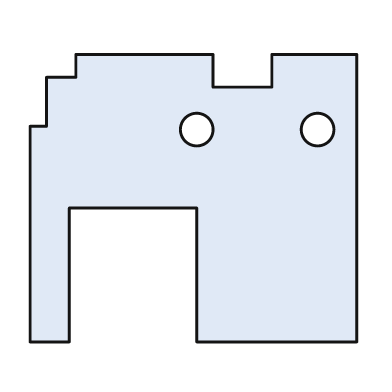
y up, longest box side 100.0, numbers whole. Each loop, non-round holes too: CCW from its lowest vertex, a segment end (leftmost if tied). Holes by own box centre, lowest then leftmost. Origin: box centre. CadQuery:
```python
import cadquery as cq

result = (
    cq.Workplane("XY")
    .moveTo(-50.0, -44.0)
    .lineTo(-38.0, -44.0)
    .lineTo(-38.0, -3.0)
    .lineTo(1.0, -3.0)
    .lineTo(1.0, -44.0)
    .lineTo(50.0, -44.0)
    .lineTo(50.0, 44.0)
    .lineTo(24.0, 44.0)
    .lineTo(24.0, 34.0)
    .lineTo(6.0, 34.0)
    .lineTo(6.0, 44.0)
    .lineTo(-36.0, 44.0)
    .lineTo(-36.0, 37.0)
    .lineTo(-45.0, 37.0)
    .lineTo(-45.0, 22.0)
    .lineTo(-50.0, 22.0)
    .close()
    .moveTo(1.0, 21.0)
    .circle(5.0)
    .moveTo(38.0, 21.0)
    .circle(5.0)
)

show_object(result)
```